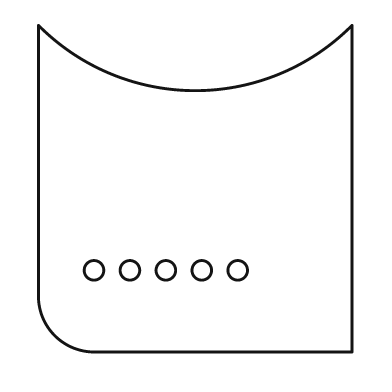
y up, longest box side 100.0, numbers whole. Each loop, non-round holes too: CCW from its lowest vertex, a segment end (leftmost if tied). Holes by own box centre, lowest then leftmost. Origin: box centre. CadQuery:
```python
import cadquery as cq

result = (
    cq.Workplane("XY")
    .moveTo(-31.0, -50.0)
    .lineTo(48.0, -50.0)
    .lineTo(48.0, 50.0)
    .threePointArc((0.0, 30.0), (-48.0, 50.0))
    .lineTo(-48.0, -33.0)
    .threePointArc((-43.0, -45.0), (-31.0, -50.0))
    .close()
    .moveTo(-31.0, -25.0)
    .circle(3.0)
    .moveTo(-20.0, -25.0)
    .circle(3.0)
    .moveTo(-9.0, -25.0)
    .circle(3.0)
    .moveTo(2.0, -25.0)
    .circle(3.0)
    .moveTo(13.0, -25.0)
    .circle(3.0)
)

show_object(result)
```